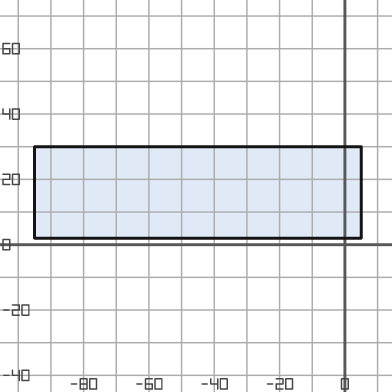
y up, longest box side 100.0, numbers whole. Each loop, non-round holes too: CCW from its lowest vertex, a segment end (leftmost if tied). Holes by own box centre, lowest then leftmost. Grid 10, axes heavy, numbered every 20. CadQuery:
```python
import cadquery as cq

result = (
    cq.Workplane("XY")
    .moveTo(-95.0, 2.0)
    .lineTo(5.0, 2.0)
    .lineTo(5.0, 30.0)
    .lineTo(-95.0, 30.0)
    .close()
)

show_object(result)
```